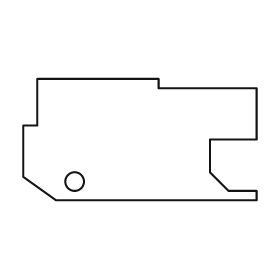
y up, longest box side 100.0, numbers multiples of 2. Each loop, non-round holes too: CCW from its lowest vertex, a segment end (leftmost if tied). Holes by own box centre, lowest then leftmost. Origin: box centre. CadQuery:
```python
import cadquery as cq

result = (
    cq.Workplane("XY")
    .moveTo(-36.0, -26.0)
    .lineTo(50.0, -26.0)
    .lineTo(50.0, -22.0)
    .lineTo(38.0, -22.0)
    .lineTo(30.0, -14.0)
    .lineTo(30.0, 0.0)
    .lineTo(50.0, 0.0)
    .lineTo(50.0, 22.0)
    .lineTo(8.0, 22.0)
    .lineTo(8.0, 26.0)
    .lineTo(-44.0, 26.0)
    .lineTo(-44.0, 6.0)
    .lineTo(-50.0, 6.0)
    .lineTo(-50.0, -16.0)
    .close()
    .moveTo(-28.0, -18.0)
    .circle(4.0)
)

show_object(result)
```